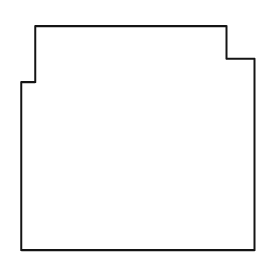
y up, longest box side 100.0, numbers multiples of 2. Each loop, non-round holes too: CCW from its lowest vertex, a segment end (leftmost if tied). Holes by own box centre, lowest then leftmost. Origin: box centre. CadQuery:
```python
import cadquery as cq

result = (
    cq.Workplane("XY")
    .moveTo(-50.0, -48.0)
    .lineTo(50.0, -48.0)
    .lineTo(50.0, 34.0)
    .lineTo(38.0, 34.0)
    .lineTo(38.0, 48.0)
    .lineTo(-44.0, 48.0)
    .lineTo(-44.0, 24.0)
    .lineTo(-50.0, 24.0)
    .close()
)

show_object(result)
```